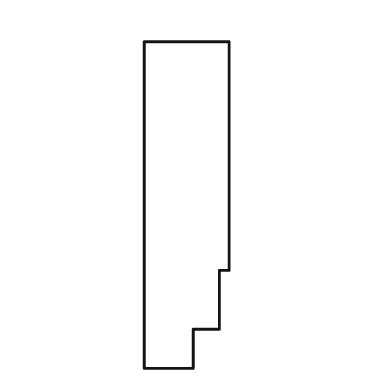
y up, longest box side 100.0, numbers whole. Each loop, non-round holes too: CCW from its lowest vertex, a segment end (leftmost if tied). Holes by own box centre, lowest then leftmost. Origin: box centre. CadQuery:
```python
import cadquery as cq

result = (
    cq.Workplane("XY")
    .moveTo(-13.0, -50.0)
    .lineTo(2.0, -50.0)
    .lineTo(2.0, -38.0)
    .lineTo(10.0, -38.0)
    .lineTo(10.0, -20.0)
    .lineTo(13.0, -20.0)
    .lineTo(13.0, 50.0)
    .lineTo(-13.0, 50.0)
    .close()
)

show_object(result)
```